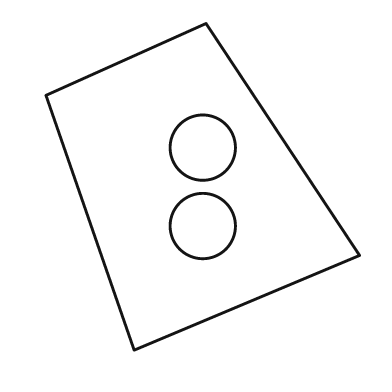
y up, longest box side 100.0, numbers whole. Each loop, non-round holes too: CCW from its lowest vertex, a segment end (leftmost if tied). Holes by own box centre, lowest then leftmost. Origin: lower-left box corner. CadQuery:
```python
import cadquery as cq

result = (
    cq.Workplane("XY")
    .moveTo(27.0, 0.0)
    .lineTo(96.0, 29.0)
    .lineTo(49.0, 100.0)
    .lineTo(0.0, 78.0)
    .close()
    .moveTo(48.0, 38.0)
    .circle(10.0)
    .moveTo(48.0, 62.0)
    .circle(10.0)
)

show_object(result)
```